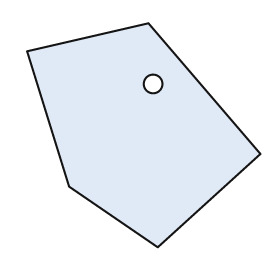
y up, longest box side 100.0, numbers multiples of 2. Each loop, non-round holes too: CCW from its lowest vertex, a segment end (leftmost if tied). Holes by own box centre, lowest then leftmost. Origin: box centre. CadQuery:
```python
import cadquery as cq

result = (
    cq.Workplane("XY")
    .moveTo(6.0, -48.0)
    .lineTo(50.0, -8.0)
    .lineTo(2.0, 48.0)
    .lineTo(-50.0, 36.0)
    .lineTo(-32.0, -22.0)
    .close()
    .moveTo(4.0, 22.0)
    .circle(4.0)
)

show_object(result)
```